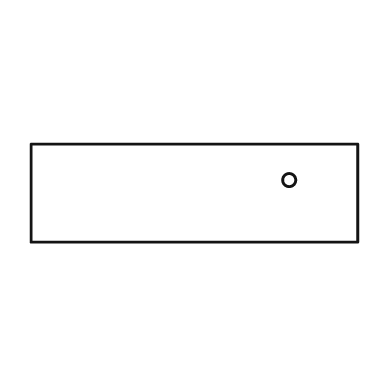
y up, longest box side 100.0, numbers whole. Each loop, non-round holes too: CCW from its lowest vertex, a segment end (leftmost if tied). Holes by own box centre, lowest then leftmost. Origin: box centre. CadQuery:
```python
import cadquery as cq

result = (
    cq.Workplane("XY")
    .moveTo(-50.0, -15.0)
    .lineTo(50.0, -15.0)
    .lineTo(50.0, 15.0)
    .lineTo(-50.0, 15.0)
    .close()
    .moveTo(29.0, 4.0)
    .circle(2.0)
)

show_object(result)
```